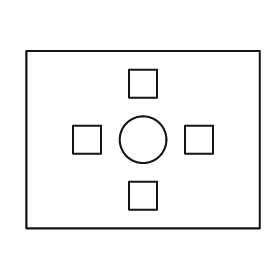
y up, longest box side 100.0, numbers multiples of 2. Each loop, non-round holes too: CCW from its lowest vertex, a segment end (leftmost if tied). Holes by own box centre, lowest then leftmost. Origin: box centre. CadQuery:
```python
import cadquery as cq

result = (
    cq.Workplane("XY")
    .moveTo(-50.0, -38.0)
    .lineTo(50.0, -38.0)
    .lineTo(50.0, 38.0)
    .lineTo(-50.0, 38.0)
    .close()
    .moveTo(-6.0, -30.0)
    .lineTo(6.0, -30.0)
    .lineTo(6.0, -18.0)
    .lineTo(-6.0, -18.0)
    .close()
    .moveTo(-30.0, -6.0)
    .lineTo(-18.0, -6.0)
    .lineTo(-18.0, 6.0)
    .lineTo(-30.0, 6.0)
    .close()
    .moveTo(0.0, 0.0)
    .circle(10.0)
    .moveTo(18.0, -6.0)
    .lineTo(30.0, -6.0)
    .lineTo(30.0, 6.0)
    .lineTo(18.0, 6.0)
    .close()
    .moveTo(-6.0, 18.0)
    .lineTo(6.0, 18.0)
    .lineTo(6.0, 30.0)
    .lineTo(-6.0, 30.0)
    .close()
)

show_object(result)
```